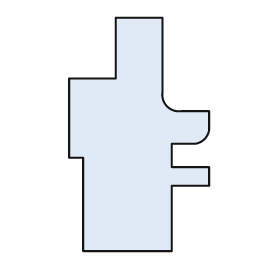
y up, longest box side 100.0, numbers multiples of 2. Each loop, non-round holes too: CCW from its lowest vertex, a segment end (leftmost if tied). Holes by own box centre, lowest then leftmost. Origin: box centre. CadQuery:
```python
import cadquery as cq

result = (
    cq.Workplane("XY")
    .moveTo(-24.0, -50.0)
    .lineTo(14.0, -50.0)
    .lineTo(14.0, -22.0)
    .lineTo(30.0, -22.0)
    .lineTo(30.0, -14.0)
    .lineTo(14.0, -14.0)
    .lineTo(14.0, -4.0)
    .lineTo(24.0, -4.0)
    .threePointArc((28.0, -2.0), (30.0, 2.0))
    .lineTo(30.0, 10.0)
    .lineTo(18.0, 10.0)
    .threePointArc((12.0, 12.0), (10.0, 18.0))
    .lineTo(10.0, 50.0)
    .lineTo(-10.0, 50.0)
    .lineTo(-10.0, 24.0)
    .lineTo(-30.0, 24.0)
    .lineTo(-30.0, -10.0)
    .lineTo(-24.0, -10.0)
    .close()
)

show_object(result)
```